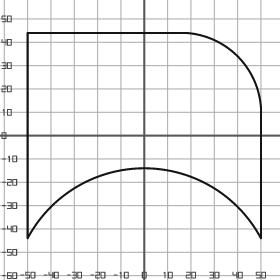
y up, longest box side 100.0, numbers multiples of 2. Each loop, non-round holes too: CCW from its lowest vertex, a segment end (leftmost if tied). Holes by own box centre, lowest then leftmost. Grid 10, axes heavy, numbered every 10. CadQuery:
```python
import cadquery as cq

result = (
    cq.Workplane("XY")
    .moveTo(-50.0, -44.0)
    .threePointArc((0.0, -14.0), (50.0, -44.0))
    .lineTo(50.0, 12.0)
    .threePointArc((40.0, 34.0), (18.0, 44.0))
    .lineTo(-50.0, 44.0)
    .close()
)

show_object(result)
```